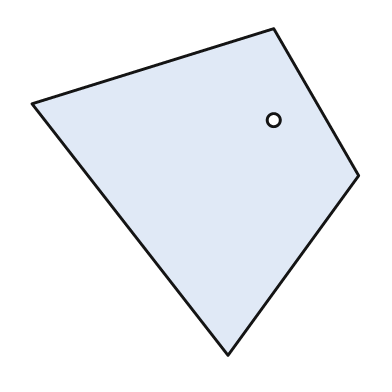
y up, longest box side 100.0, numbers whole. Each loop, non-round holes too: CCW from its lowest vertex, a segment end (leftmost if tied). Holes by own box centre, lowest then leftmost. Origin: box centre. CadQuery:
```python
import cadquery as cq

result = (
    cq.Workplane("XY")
    .moveTo(10.0, -50.0)
    .lineTo(50.0, 5.0)
    .lineTo(24.0, 50.0)
    .lineTo(-50.0, 27.0)
    .close()
    .moveTo(24.0, 22.0)
    .circle(2.0)
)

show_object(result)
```